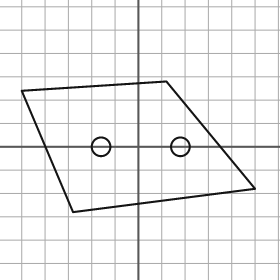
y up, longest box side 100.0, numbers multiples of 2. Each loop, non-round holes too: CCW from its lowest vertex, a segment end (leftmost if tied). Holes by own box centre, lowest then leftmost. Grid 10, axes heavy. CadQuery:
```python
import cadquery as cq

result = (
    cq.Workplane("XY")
    .moveTo(-28.0, -28.0)
    .lineTo(50.0, -18.0)
    .lineTo(12.0, 28.0)
    .lineTo(-50.0, 24.0)
    .close()
    .moveTo(-16.0, 0.0)
    .circle(4.0)
    .moveTo(18.0, 0.0)
    .circle(4.0)
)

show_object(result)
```